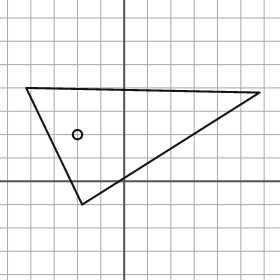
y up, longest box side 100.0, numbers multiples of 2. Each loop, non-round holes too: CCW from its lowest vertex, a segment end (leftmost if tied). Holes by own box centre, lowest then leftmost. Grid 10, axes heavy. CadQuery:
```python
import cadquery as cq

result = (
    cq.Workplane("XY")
    .moveTo(-18.0, -10.0)
    .lineTo(58.0, 38.0)
    .lineTo(-42.0, 40.0)
    .close()
    .moveTo(-20.0, 20.0)
    .circle(2.0)
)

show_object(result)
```